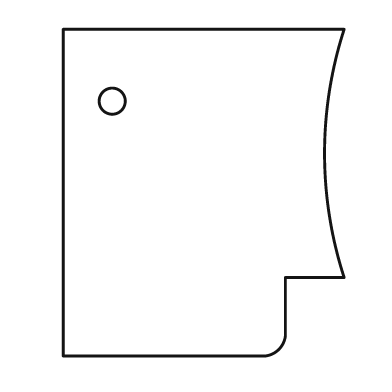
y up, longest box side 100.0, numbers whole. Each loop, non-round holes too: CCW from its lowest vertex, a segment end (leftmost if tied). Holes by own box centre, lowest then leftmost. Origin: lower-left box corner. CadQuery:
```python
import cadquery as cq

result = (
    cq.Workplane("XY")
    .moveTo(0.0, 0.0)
    .lineTo(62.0, 0.0)
    .threePointArc((66.0, 2.0), (68.0, 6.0))
    .lineTo(68.0, 24.0)
    .lineTo(86.0, 24.0)
    .threePointArc((80.0, 62.0), (86.0, 100.0))
    .lineTo(0.0, 100.0)
    .close()
    .moveTo(15.0, 78.0)
    .circle(4.0)
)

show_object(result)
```